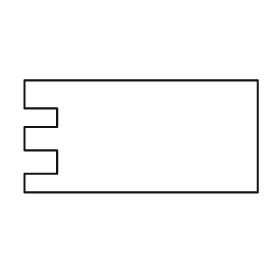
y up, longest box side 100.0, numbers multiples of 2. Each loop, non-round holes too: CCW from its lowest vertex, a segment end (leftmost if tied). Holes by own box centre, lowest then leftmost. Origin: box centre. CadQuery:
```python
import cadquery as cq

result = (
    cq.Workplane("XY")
    .moveTo(-50.0, -24.0)
    .lineTo(50.0, -24.0)
    .lineTo(50.0, 24.0)
    .lineTo(-50.0, 24.0)
    .lineTo(-50.0, 12.0)
    .lineTo(-36.0, 12.0)
    .lineTo(-36.0, 4.0)
    .lineTo(-50.0, 4.0)
    .lineTo(-50.0, -6.0)
    .lineTo(-36.0, -6.0)
    .lineTo(-36.0, -16.0)
    .lineTo(-50.0, -16.0)
    .close()
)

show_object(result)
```